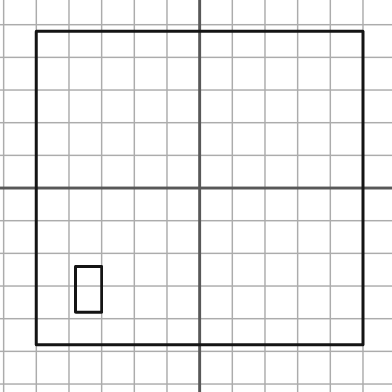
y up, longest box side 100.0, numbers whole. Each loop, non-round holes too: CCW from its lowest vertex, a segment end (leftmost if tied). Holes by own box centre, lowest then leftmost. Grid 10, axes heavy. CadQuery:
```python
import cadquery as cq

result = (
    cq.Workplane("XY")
    .moveTo(-50.0, -48.0)
    .lineTo(50.0, -48.0)
    .lineTo(50.0, 48.0)
    .lineTo(-50.0, 48.0)
    .close()
    .moveTo(-38.0, -38.0)
    .lineTo(-30.0, -38.0)
    .lineTo(-30.0, -24.0)
    .lineTo(-38.0, -24.0)
    .close()
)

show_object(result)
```